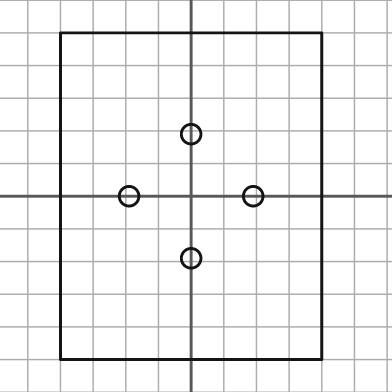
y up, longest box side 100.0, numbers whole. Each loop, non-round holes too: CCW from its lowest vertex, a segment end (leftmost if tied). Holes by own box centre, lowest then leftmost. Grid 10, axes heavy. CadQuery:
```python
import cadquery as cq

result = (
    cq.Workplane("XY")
    .moveTo(-40.0, -50.0)
    .lineTo(40.0, -50.0)
    .lineTo(40.0, 50.0)
    .lineTo(-40.0, 50.0)
    .close()
    .moveTo(0.0, -19.0)
    .circle(3.0)
    .moveTo(-19.0, 0.0)
    .circle(3.0)
    .moveTo(19.0, 0.0)
    .circle(3.0)
    .moveTo(0.0, 19.0)
    .circle(3.0)
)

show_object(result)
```